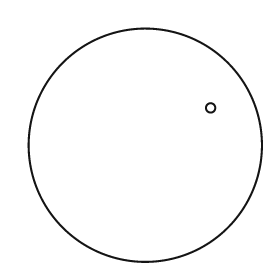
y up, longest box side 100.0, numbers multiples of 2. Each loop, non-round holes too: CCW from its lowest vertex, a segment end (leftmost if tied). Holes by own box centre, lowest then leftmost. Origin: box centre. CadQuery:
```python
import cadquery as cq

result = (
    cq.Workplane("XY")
    .moveTo(0.0, 0.0)
    .circle(50.0)
    .moveTo(28.0, 16.0)
    .circle(2.0)
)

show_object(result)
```